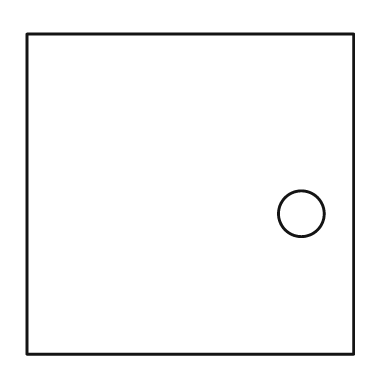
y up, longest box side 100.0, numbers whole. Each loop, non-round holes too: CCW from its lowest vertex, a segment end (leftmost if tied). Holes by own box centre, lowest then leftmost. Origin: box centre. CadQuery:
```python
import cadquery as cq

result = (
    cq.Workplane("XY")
    .moveTo(-50.0, -49.0)
    .lineTo(50.0, -49.0)
    .lineTo(50.0, 49.0)
    .lineTo(-50.0, 49.0)
    .close()
    .moveTo(34.0, -6.0)
    .circle(7.0)
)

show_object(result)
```